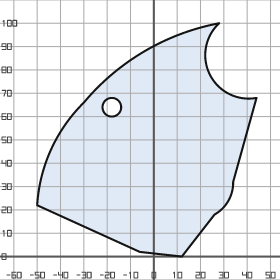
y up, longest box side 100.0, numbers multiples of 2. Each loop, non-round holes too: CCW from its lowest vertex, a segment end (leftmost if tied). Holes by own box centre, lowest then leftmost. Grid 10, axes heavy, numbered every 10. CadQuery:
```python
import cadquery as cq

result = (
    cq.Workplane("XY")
    .moveTo(12.0, 0.0)
    .lineTo(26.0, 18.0)
    .threePointArc((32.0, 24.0), (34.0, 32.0))
    .lineTo(44.0, 68.0)
    .threePointArc((24.0, 78.0), (28.0, 100.0))
    .threePointArc((-4.0, 88.0), (-30.0, 66.0))
    .threePointArc((-44.0, 46.0), (-50.0, 22.0))
    .lineTo(-6.0, 2.0)
    .close()
    .moveTo(-18.0, 64.0)
    .circle(4.0)
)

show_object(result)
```